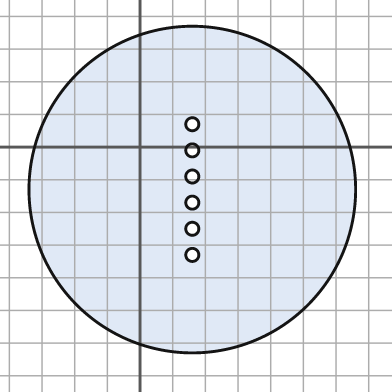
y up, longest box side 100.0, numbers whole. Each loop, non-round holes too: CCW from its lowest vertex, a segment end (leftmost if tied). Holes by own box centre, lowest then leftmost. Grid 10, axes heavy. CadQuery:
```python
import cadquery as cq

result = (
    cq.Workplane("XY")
    .moveTo(16.0, -13.0)
    .circle(50.0)
    .moveTo(16.0, -33.0)
    .circle(2.0)
    .moveTo(16.0, -25.0)
    .circle(2.0)
    .moveTo(16.0, -17.0)
    .circle(2.0)
    .moveTo(16.0, -9.0)
    .circle(2.0)
    .moveTo(16.0, -1.0)
    .circle(2.0)
    .moveTo(16.0, 7.0)
    .circle(2.0)
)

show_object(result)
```